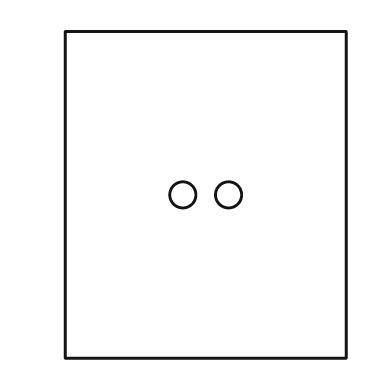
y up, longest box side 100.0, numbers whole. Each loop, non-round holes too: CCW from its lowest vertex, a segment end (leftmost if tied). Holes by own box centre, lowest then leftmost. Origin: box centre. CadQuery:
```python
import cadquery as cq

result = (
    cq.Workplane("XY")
    .moveTo(-43.0, -50.0)
    .lineTo(43.0, -50.0)
    .lineTo(43.0, 50.0)
    .lineTo(-43.0, 50.0)
    .close()
    .moveTo(-7.0, 0.0)
    .circle(4.0)
    .moveTo(7.0, 0.0)
    .circle(4.0)
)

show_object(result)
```